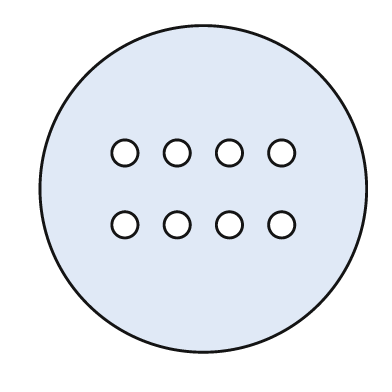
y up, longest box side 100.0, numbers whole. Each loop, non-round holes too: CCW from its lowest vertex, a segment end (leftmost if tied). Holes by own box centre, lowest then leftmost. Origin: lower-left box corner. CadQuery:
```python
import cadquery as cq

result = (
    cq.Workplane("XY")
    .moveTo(50.0, 50.0)
    .circle(50.0)
    .moveTo(26.0, 39.0)
    .circle(4.0)
    .moveTo(42.0, 39.0)
    .circle(4.0)
    .moveTo(58.0, 39.0)
    .circle(4.0)
    .moveTo(74.0, 39.0)
    .circle(4.0)
    .moveTo(26.0, 61.0)
    .circle(4.0)
    .moveTo(42.0, 61.0)
    .circle(4.0)
    .moveTo(58.0, 61.0)
    .circle(4.0)
    .moveTo(74.0, 61.0)
    .circle(4.0)
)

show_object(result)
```